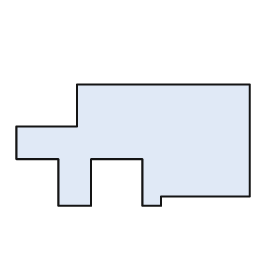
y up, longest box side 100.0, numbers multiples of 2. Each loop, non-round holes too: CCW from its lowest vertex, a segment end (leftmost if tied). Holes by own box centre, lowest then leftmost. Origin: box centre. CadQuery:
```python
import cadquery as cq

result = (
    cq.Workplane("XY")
    .moveTo(-32.0, -26.0)
    .lineTo(-18.0, -26.0)
    .lineTo(-18.0, -6.0)
    .lineTo(4.0, -6.0)
    .lineTo(4.0, -26.0)
    .lineTo(12.0, -26.0)
    .lineTo(12.0, -22.0)
    .lineTo(50.0, -22.0)
    .lineTo(50.0, 26.0)
    .lineTo(-24.0, 26.0)
    .lineTo(-24.0, 8.0)
    .lineTo(-50.0, 8.0)
    .lineTo(-50.0, -6.0)
    .lineTo(-32.0, -6.0)
    .close()
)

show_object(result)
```